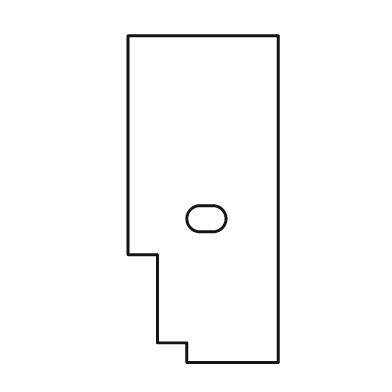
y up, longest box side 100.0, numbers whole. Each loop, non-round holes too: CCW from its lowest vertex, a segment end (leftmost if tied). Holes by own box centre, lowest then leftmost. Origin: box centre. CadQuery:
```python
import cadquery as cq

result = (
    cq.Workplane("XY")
    .moveTo(-5.0, -50.0)
    .lineTo(23.0, -50.0)
    .lineTo(23.0, 50.0)
    .lineTo(-23.0, 50.0)
    .lineTo(-23.0, -17.0)
    .lineTo(-14.0, -17.0)
    .lineTo(-14.0, -44.0)
    .lineTo(-5.0, -44.0)
    .close()
    .moveTo(-1.0, -10.0)
    .lineTo(3.0, -10.0)
    .threePointArc((7.0, -6.0), (3.0, -2.0))
    .lineTo(-1.0, -2.0)
    .threePointArc((-5.0, -6.0), (-1.0, -10.0))
    .close()
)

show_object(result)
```